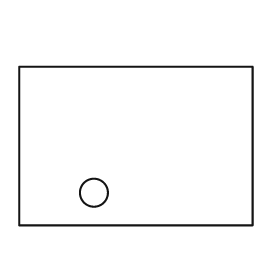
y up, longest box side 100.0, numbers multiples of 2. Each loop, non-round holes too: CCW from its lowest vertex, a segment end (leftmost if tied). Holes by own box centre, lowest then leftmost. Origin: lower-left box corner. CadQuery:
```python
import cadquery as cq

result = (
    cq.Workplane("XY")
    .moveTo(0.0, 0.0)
    .lineTo(100.0, 0.0)
    .lineTo(100.0, 68.0)
    .lineTo(0.0, 68.0)
    .close()
    .moveTo(32.0, 14.0)
    .circle(6.0)
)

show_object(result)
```